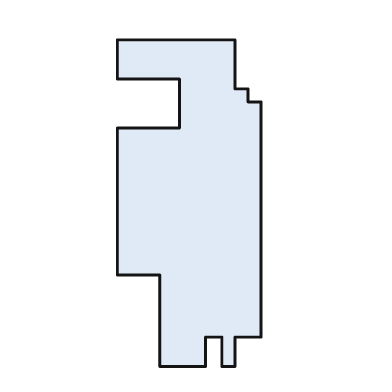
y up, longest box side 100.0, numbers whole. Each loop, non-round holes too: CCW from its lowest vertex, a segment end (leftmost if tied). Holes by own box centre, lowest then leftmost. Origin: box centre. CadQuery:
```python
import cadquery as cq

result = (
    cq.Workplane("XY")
    .moveTo(-9.0, -50.0)
    .lineTo(5.0, -50.0)
    .lineTo(5.0, -41.0)
    .lineTo(10.0, -41.0)
    .lineTo(10.0, -50.0)
    .lineTo(14.0, -50.0)
    .lineTo(14.0, -41.0)
    .lineTo(22.0, -41.0)
    .lineTo(22.0, 31.0)
    .lineTo(18.0, 31.0)
    .lineTo(18.0, 35.0)
    .lineTo(14.0, 35.0)
    .lineTo(14.0, 50.0)
    .lineTo(-22.0, 50.0)
    .lineTo(-22.0, 38.0)
    .lineTo(-3.0, 38.0)
    .lineTo(-3.0, 23.0)
    .lineTo(-22.0, 23.0)
    .lineTo(-22.0, -22.0)
    .lineTo(-9.0, -22.0)
    .close()
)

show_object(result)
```